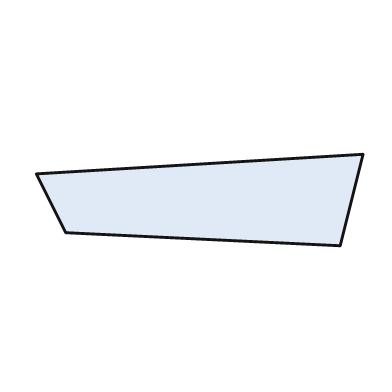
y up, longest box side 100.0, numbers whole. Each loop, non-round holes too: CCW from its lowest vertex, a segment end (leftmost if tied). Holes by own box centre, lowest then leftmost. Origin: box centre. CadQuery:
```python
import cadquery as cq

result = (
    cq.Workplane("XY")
    .moveTo(43.0, -14.0)
    .lineTo(50.0, 14.0)
    .lineTo(-50.0, 8.0)
    .lineTo(-41.0, -10.0)
    .close()
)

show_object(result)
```